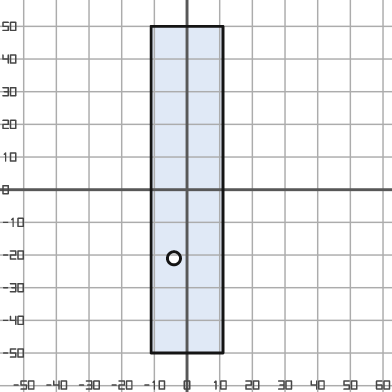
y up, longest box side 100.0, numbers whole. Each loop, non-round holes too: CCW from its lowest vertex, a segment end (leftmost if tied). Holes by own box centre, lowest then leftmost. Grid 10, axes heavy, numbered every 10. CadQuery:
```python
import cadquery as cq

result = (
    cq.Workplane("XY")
    .moveTo(-11.0, -50.0)
    .lineTo(11.0, -50.0)
    .lineTo(11.0, 50.0)
    .lineTo(-11.0, 50.0)
    .close()
    .moveTo(-4.0, -21.0)
    .circle(2.0)
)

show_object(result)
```